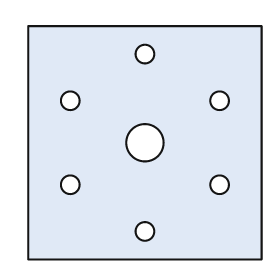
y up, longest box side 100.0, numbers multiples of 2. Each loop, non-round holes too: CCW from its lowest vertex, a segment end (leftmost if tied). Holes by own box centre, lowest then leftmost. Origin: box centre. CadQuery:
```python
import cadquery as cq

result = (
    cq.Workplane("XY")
    .moveTo(-50.0, -50.0)
    .lineTo(50.0, -50.0)
    .lineTo(50.0, 50.0)
    .lineTo(-50.0, 50.0)
    .close()
    .moveTo(0.0, -38.0)
    .circle(4.0)
    .moveTo(-32.0, -18.0)
    .circle(4.0)
    .moveTo(32.0, -18.0)
    .circle(4.0)
    .moveTo(0.0, 0.0)
    .circle(8.0)
    .moveTo(-32.0, 18.0)
    .circle(4.0)
    .moveTo(32.0, 18.0)
    .circle(4.0)
    .moveTo(0.0, 38.0)
    .circle(4.0)
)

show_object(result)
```